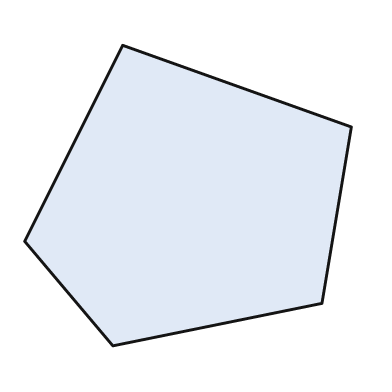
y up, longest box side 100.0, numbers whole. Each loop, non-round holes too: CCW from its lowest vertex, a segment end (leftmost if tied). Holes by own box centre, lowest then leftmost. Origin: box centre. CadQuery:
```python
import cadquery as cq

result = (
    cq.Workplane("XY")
    .moveTo(-23.0, -46.0)
    .lineTo(41.0, -33.0)
    .lineTo(50.0, 21.0)
    .lineTo(-20.0, 46.0)
    .lineTo(-50.0, -14.0)
    .close()
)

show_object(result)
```